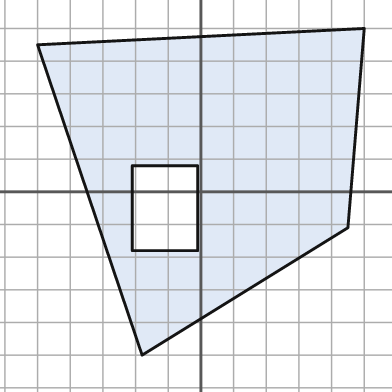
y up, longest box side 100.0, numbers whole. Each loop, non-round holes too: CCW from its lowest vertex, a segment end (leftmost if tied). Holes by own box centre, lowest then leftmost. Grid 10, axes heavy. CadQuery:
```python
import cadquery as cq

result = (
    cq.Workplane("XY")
    .moveTo(-18.0, -50.0)
    .lineTo(45.0, -11.0)
    .lineTo(50.0, 50.0)
    .lineTo(-50.0, 45.0)
    .close()
    .moveTo(-21.0, -18.0)
    .lineTo(-1.0, -18.0)
    .lineTo(-1.0, 8.0)
    .lineTo(-21.0, 8.0)
    .close()
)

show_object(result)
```